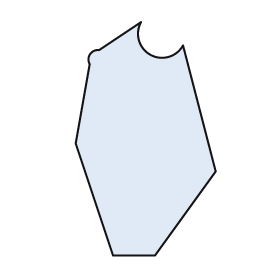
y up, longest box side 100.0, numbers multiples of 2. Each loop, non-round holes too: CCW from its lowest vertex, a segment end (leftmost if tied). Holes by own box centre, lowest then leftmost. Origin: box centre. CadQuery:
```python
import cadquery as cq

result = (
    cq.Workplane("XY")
    .moveTo(-14.0, -50.0)
    .lineTo(4.0, -50.0)
    .lineTo(30.0, -14.0)
    .lineTo(16.0, 40.0)
    .threePointArc((2.0, 36.0), (-2.0, 50.0))
    .lineTo(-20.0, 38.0)
    .threePointArc((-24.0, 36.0), (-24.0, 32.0))
    .lineTo(-30.0, -2.0)
    .close()
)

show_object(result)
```